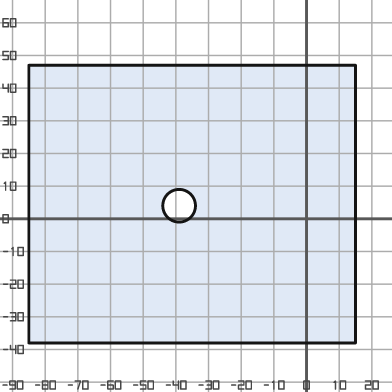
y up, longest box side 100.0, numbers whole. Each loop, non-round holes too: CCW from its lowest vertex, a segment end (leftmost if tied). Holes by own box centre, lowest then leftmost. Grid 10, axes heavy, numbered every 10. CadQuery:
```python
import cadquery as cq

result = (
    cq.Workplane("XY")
    .moveTo(-85.0, -38.0)
    .lineTo(15.0, -38.0)
    .lineTo(15.0, 47.0)
    .lineTo(-85.0, 47.0)
    .close()
    .moveTo(-39.0, 4.0)
    .circle(5.0)
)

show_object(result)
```